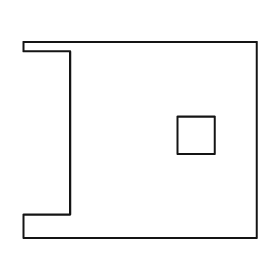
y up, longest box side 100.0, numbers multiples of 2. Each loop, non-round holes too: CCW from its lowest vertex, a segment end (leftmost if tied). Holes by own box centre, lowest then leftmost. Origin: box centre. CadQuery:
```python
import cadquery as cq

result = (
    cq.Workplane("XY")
    .moveTo(-50.0, -42.0)
    .lineTo(50.0, -42.0)
    .lineTo(50.0, 42.0)
    .lineTo(-50.0, 42.0)
    .lineTo(-50.0, 38.0)
    .lineTo(-30.0, 38.0)
    .lineTo(-30.0, -32.0)
    .lineTo(-50.0, -32.0)
    .close()
    .moveTo(16.0, -6.0)
    .lineTo(32.0, -6.0)
    .lineTo(32.0, 10.0)
    .lineTo(16.0, 10.0)
    .close()
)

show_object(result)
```